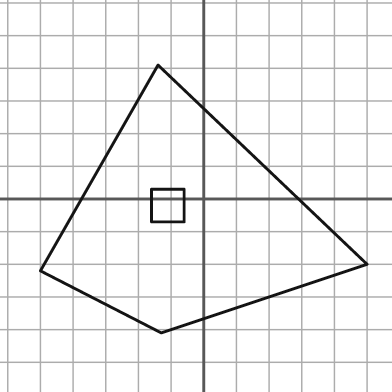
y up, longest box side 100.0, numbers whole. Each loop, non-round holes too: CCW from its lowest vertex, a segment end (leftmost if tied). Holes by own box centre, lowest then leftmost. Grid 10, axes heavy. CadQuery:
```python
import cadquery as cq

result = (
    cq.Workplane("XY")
    .moveTo(-13.0, -41.0)
    .lineTo(50.0, -20.0)
    .lineTo(-14.0, 41.0)
    .lineTo(-50.0, -22.0)
    .close()
    .moveTo(-16.0, -7.0)
    .lineTo(-6.0, -7.0)
    .lineTo(-6.0, 3.0)
    .lineTo(-16.0, 3.0)
    .close()
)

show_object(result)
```